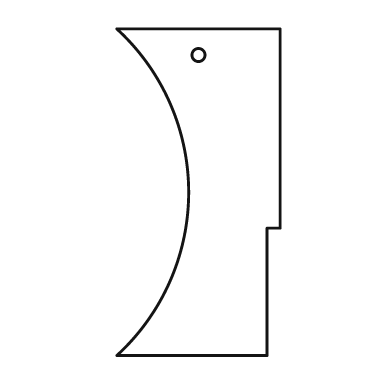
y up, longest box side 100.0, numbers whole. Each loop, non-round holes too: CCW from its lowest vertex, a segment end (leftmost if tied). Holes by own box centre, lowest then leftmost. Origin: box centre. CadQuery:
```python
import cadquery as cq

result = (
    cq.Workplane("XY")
    .moveTo(-25.0, -50.0)
    .lineTo(21.0, -50.0)
    .lineTo(21.0, -11.0)
    .lineTo(25.0, -11.0)
    .lineTo(25.0, 50.0)
    .lineTo(-25.0, 50.0)
    .threePointArc((-3.0, 0.0), (-25.0, -50.0))
    .close()
    .moveTo(0.0, 42.0)
    .circle(2.0)
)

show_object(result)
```